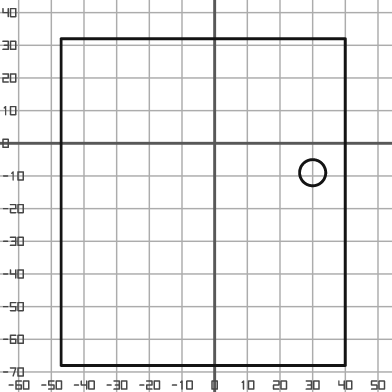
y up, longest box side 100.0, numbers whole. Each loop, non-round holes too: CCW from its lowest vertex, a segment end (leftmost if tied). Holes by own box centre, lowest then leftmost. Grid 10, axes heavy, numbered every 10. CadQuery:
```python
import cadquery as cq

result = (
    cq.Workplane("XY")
    .moveTo(-47.0, -68.0)
    .lineTo(40.0, -68.0)
    .lineTo(40.0, 32.0)
    .lineTo(-47.0, 32.0)
    .close()
    .moveTo(30.0, -9.0)
    .circle(4.0)
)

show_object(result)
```